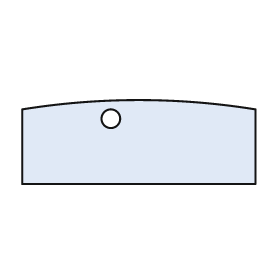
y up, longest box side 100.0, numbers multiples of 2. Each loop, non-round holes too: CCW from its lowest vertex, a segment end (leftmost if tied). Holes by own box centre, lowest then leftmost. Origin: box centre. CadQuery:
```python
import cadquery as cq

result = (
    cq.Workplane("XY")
    .moveTo(-50.0, -18.0)
    .lineTo(50.0, -18.0)
    .lineTo(50.0, 14.0)
    .threePointArc((0.0, 18.0), (-50.0, 14.0))
    .close()
    .moveTo(-12.0, 10.0)
    .circle(4.0)
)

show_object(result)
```